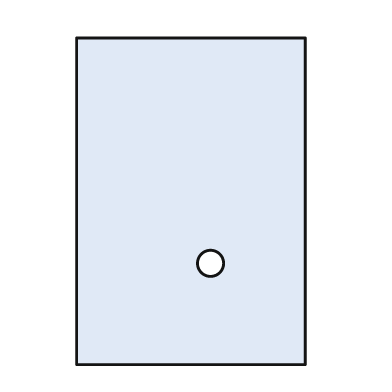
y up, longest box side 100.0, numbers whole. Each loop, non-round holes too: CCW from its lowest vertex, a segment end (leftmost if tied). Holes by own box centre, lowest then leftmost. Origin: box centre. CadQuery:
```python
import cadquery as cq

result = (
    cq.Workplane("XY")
    .moveTo(-35.0, -50.0)
    .lineTo(35.0, -50.0)
    .lineTo(35.0, 50.0)
    .lineTo(-35.0, 50.0)
    .close()
    .moveTo(6.0, -19.0)
    .circle(4.0)
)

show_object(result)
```